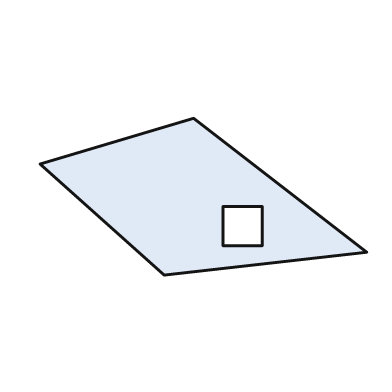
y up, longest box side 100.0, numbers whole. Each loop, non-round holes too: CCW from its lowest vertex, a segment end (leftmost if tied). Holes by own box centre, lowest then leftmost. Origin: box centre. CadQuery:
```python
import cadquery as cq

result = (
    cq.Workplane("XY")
    .moveTo(-12.0, -24.0)
    .lineTo(50.0, -17.0)
    .lineTo(-3.0, 24.0)
    .lineTo(-50.0, 10.0)
    .close()
    .moveTo(6.0, -15.0)
    .lineTo(18.0, -15.0)
    .lineTo(18.0, -3.0)
    .lineTo(6.0, -3.0)
    .close()
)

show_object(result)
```